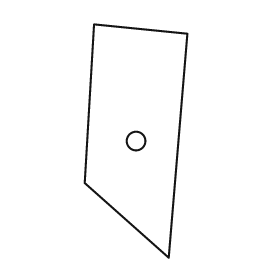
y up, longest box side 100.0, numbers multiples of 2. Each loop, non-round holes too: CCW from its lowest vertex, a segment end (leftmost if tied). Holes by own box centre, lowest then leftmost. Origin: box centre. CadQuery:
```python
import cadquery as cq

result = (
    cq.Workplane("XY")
    .moveTo(14.0, -50.0)
    .lineTo(22.0, 46.0)
    .lineTo(-18.0, 50.0)
    .lineTo(-22.0, -18.0)
    .close()
    .moveTo(0.0, 0.0)
    .circle(4.0)
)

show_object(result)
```